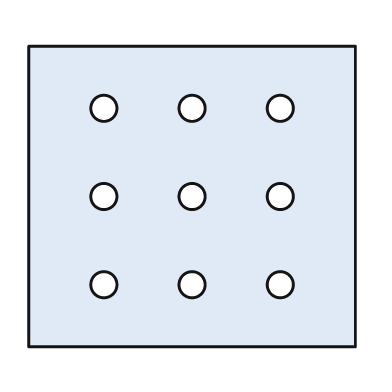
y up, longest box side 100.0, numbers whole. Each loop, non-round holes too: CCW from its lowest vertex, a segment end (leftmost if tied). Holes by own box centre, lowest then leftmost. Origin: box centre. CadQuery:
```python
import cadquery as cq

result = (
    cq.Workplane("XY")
    .moveTo(-50.0, -46.0)
    .lineTo(50.0, -46.0)
    .lineTo(50.0, 46.0)
    .lineTo(-50.0, 46.0)
    .close()
    .moveTo(-27.0, -27.0)
    .circle(4.0)
    .moveTo(0.0, -27.0)
    .circle(4.0)
    .moveTo(27.0, -27.0)
    .circle(4.0)
    .moveTo(-27.0, 0.0)
    .circle(4.0)
    .moveTo(0.0, 0.0)
    .circle(4.0)
    .moveTo(27.0, 0.0)
    .circle(4.0)
    .moveTo(-27.0, 27.0)
    .circle(4.0)
    .moveTo(0.0, 27.0)
    .circle(4.0)
    .moveTo(27.0, 27.0)
    .circle(4.0)
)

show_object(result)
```